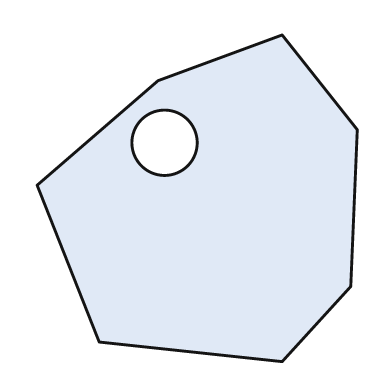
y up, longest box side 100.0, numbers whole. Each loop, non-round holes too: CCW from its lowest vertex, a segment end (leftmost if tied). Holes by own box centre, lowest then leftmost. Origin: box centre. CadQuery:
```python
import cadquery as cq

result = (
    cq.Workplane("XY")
    .moveTo(26.0, -50.0)
    .lineTo(47.0, -27.0)
    .lineTo(49.0, 21.0)
    .lineTo(26.0, 50.0)
    .lineTo(-12.0, 36.0)
    .lineTo(-49.0, 4.0)
    .lineTo(-30.0, -44.0)
    .close()
    .moveTo(-10.0, 17.0)
    .circle(10.0)
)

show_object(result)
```